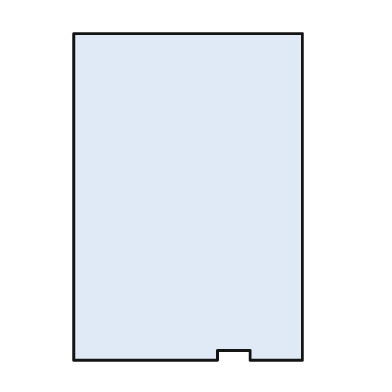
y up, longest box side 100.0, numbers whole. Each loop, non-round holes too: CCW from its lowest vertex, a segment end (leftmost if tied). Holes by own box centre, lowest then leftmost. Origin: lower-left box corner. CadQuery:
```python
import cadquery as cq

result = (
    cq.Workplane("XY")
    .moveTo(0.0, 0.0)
    .lineTo(44.0, 0.0)
    .lineTo(44.0, 3.0)
    .lineTo(54.0, 3.0)
    .lineTo(54.0, 0.0)
    .lineTo(70.0, 0.0)
    .lineTo(70.0, 100.0)
    .lineTo(0.0, 100.0)
    .close()
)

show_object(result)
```